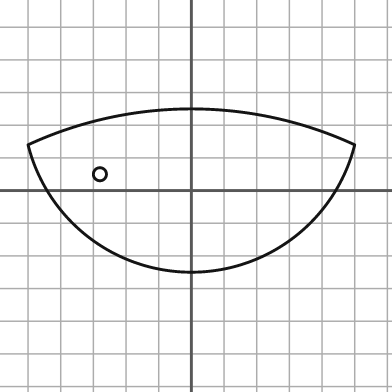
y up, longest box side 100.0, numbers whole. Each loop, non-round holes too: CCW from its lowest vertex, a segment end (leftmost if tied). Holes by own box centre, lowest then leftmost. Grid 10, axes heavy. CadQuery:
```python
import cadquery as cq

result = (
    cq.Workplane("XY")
    .moveTo(-50.0, 14.0)
    .threePointArc((0.0, -25.0), (50.0, 14.0))
    .threePointArc((0.0, 25.0), (-50.0, 14.0))
    .close()
    .moveTo(-28.0, 5.0)
    .circle(2.0)
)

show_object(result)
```